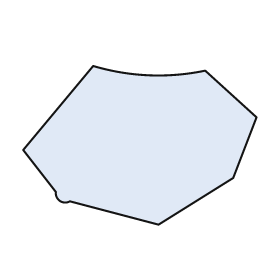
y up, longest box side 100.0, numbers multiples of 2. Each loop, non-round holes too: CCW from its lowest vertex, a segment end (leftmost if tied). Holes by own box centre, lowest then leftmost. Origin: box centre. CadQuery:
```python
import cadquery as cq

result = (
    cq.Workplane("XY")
    .moveTo(8.0, -34.0)
    .lineTo(40.0, -14.0)
    .lineTo(50.0, 12.0)
    .lineTo(28.0, 32.0)
    .threePointArc((4.0, 30.0), (-20.0, 34.0))
    .lineTo(-50.0, -2.0)
    .lineTo(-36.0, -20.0)
    .threePointArc((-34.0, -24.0), (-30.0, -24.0))
    .close()
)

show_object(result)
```